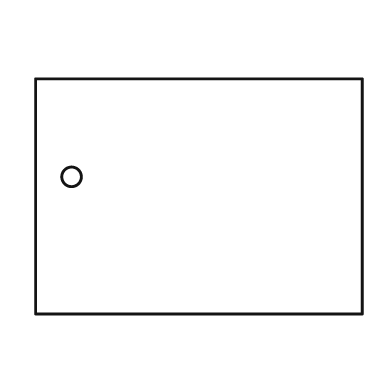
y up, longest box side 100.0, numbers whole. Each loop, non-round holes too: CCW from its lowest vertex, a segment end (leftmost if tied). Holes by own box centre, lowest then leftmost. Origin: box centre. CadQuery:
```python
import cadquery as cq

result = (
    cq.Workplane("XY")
    .moveTo(-50.0, -36.0)
    .lineTo(50.0, -36.0)
    .lineTo(50.0, 36.0)
    .lineTo(-50.0, 36.0)
    .close()
    .moveTo(-39.0, 6.0)
    .circle(3.0)
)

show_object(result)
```